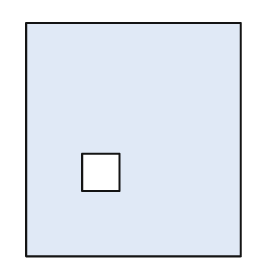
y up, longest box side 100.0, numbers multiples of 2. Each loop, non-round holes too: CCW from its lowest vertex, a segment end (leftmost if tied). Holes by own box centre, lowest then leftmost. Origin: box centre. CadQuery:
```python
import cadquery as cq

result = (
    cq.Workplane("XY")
    .moveTo(-46.0, -50.0)
    .lineTo(46.0, -50.0)
    .lineTo(46.0, 50.0)
    .lineTo(-46.0, 50.0)
    .close()
    .moveTo(-22.0, -22.0)
    .lineTo(-6.0, -22.0)
    .lineTo(-6.0, -6.0)
    .lineTo(-22.0, -6.0)
    .close()
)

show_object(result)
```